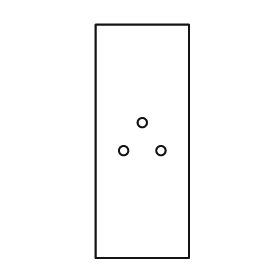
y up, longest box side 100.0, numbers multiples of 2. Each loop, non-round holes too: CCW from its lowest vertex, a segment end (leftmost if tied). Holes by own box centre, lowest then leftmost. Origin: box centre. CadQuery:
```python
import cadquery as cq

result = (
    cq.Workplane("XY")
    .moveTo(-20.0, -50.0)
    .lineTo(20.0, -50.0)
    .lineTo(20.0, 50.0)
    .lineTo(-20.0, 50.0)
    .close()
    .moveTo(-8.0, -4.0)
    .circle(2.0)
    .moveTo(8.0, -4.0)
    .circle(2.0)
    .moveTo(0.0, 8.0)
    .circle(2.0)
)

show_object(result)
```